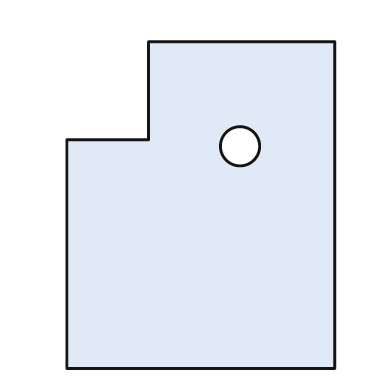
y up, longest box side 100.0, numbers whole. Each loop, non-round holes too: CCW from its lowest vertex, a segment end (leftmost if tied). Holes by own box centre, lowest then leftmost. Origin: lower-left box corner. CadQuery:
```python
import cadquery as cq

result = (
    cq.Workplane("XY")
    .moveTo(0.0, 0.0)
    .lineTo(82.0, 0.0)
    .lineTo(82.0, 100.0)
    .lineTo(25.0, 100.0)
    .lineTo(25.0, 70.0)
    .lineTo(0.0, 70.0)
    .close()
    .moveTo(53.0, 68.0)
    .circle(6.0)
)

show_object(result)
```